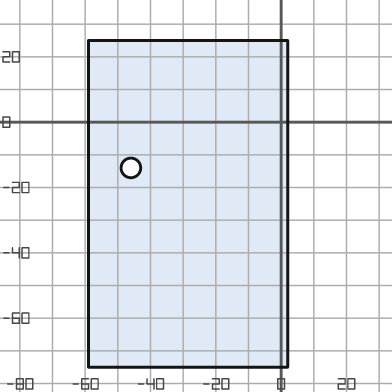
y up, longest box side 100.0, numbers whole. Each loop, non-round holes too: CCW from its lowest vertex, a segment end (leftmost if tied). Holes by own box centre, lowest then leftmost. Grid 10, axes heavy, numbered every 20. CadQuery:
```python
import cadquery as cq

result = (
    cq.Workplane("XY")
    .moveTo(-59.0, -75.0)
    .lineTo(2.0, -75.0)
    .lineTo(2.0, 25.0)
    .lineTo(-59.0, 25.0)
    .close()
    .moveTo(-46.0, -14.0)
    .circle(3.0)
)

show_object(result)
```